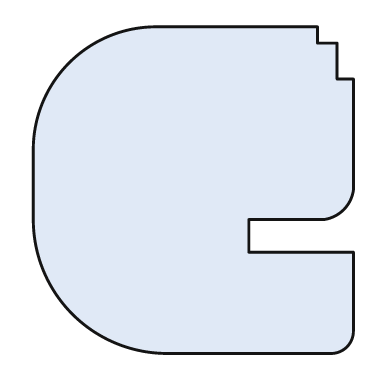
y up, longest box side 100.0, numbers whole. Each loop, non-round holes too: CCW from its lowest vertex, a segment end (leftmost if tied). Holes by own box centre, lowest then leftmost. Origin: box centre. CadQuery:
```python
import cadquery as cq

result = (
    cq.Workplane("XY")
    .moveTo(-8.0, -50.0)
    .lineTo(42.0, -50.0)
    .threePointArc((47.0, -48.0), (49.0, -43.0))
    .lineTo(49.0, -19.0)
    .lineTo(17.0, -19.0)
    .lineTo(17.0, -9.0)
    .lineTo(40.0, -9.0)
    .threePointArc((46.0, -6.0), (49.0, 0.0))
    .lineTo(49.0, 34.0)
    .lineTo(44.0, 34.0)
    .lineTo(44.0, 45.0)
    .lineTo(38.0, 45.0)
    .lineTo(38.0, 50.0)
    .lineTo(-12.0, 50.0)
    .threePointArc((-38.0, 39.0), (-49.0, 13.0))
    .lineTo(-49.0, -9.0)
    .threePointArc((-37.0, -38.0), (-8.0, -50.0))
    .close()
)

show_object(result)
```